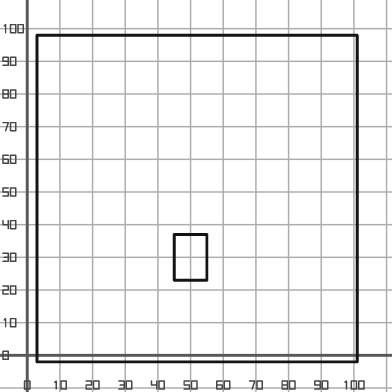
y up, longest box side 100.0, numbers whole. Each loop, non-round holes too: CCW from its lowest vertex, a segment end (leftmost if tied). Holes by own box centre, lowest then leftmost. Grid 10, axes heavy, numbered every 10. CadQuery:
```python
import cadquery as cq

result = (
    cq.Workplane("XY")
    .moveTo(3.0, -2.0)
    .lineTo(101.0, -2.0)
    .lineTo(101.0, 98.0)
    .lineTo(3.0, 98.0)
    .close()
    .moveTo(45.0, 23.0)
    .lineTo(55.0, 23.0)
    .lineTo(55.0, 37.0)
    .lineTo(45.0, 37.0)
    .close()
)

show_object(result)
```